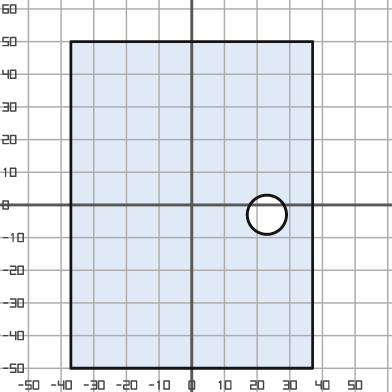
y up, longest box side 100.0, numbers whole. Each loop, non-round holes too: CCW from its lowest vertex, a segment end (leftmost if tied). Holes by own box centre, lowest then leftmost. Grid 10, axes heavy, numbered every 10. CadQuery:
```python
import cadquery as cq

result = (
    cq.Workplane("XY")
    .moveTo(-37.0, -50.0)
    .lineTo(37.0, -50.0)
    .lineTo(37.0, 50.0)
    .lineTo(-37.0, 50.0)
    .close()
    .moveTo(23.0, -3.0)
    .circle(6.0)
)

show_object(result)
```